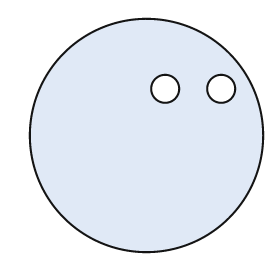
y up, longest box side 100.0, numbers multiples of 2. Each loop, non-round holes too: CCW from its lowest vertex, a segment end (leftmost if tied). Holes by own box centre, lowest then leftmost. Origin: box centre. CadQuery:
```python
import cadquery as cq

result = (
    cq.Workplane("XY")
    .moveTo(0.0, 0.0)
    .circle(50.0)
    .moveTo(8.0, 20.0)
    .circle(6.0)
    .moveTo(32.0, 20.0)
    .circle(6.0)
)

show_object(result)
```